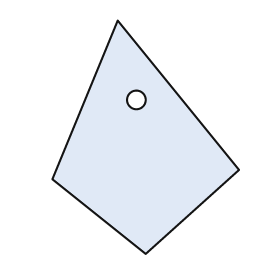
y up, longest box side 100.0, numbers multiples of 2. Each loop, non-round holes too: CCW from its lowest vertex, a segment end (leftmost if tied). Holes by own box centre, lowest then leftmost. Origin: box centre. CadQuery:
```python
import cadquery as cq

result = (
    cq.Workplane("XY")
    .moveTo(0.0, -50.0)
    .lineTo(40.0, -14.0)
    .lineTo(-12.0, 50.0)
    .lineTo(-40.0, -18.0)
    .close()
    .moveTo(-4.0, 16.0)
    .circle(4.0)
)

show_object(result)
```